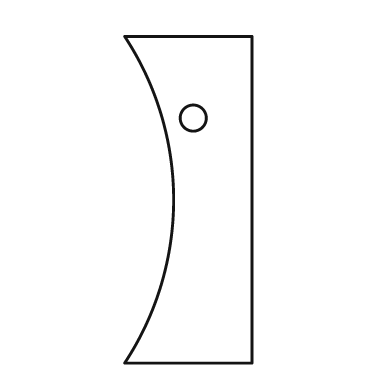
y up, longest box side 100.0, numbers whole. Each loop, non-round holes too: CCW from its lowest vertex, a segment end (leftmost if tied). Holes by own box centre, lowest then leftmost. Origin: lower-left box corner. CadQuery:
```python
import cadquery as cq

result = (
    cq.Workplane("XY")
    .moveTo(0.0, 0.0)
    .lineTo(39.0, 0.0)
    .lineTo(39.0, 100.0)
    .lineTo(0.0, 100.0)
    .threePointArc((15.0, 50.0), (0.0, 0.0))
    .close()
    .moveTo(21.0, 75.0)
    .circle(4.0)
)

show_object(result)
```